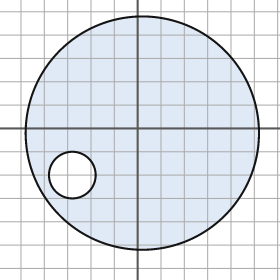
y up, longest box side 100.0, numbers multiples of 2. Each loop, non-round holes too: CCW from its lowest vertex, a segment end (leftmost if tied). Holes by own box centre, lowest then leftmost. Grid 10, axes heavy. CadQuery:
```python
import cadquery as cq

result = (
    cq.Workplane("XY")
    .moveTo(2.0, -2.0)
    .circle(50.0)
    .moveTo(-28.0, -20.0)
    .circle(10.0)
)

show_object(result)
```